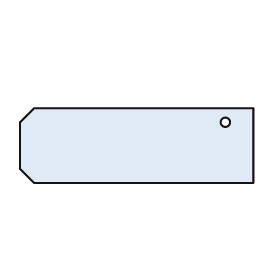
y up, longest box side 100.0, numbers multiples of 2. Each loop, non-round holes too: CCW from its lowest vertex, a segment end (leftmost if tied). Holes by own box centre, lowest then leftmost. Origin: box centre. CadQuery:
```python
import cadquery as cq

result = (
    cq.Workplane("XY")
    .moveTo(-44.0, -16.0)
    .lineTo(50.0, -16.0)
    .lineTo(50.0, 16.0)
    .lineTo(-44.0, 16.0)
    .lineTo(-50.0, 10.0)
    .lineTo(-50.0, -10.0)
    .close()
    .moveTo(38.0, 10.0)
    .circle(2.0)
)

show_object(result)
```